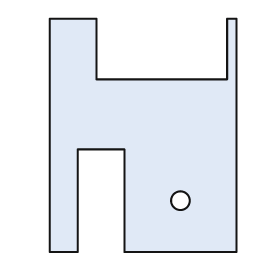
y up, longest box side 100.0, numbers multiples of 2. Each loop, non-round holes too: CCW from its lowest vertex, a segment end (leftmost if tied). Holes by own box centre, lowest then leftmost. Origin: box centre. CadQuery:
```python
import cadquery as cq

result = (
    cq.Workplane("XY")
    .moveTo(-40.0, -50.0)
    .lineTo(-28.0, -50.0)
    .lineTo(-28.0, -6.0)
    .lineTo(-8.0, -6.0)
    .lineTo(-8.0, -50.0)
    .lineTo(40.0, -50.0)
    .lineTo(40.0, 50.0)
    .lineTo(36.0, 50.0)
    .lineTo(36.0, 24.0)
    .lineTo(-20.0, 24.0)
    .lineTo(-20.0, 50.0)
    .lineTo(-40.0, 50.0)
    .close()
    .moveTo(16.0, -28.0)
    .circle(4.0)
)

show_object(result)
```